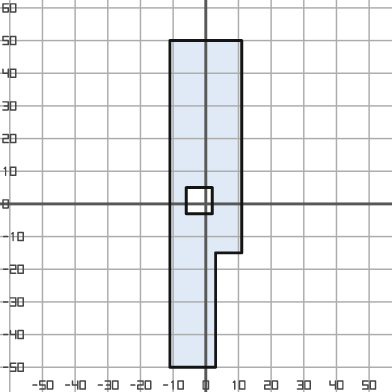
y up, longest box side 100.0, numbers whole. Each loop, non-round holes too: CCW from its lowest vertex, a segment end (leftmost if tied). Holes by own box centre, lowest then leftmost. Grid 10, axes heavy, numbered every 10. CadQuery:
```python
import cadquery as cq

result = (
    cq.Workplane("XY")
    .moveTo(-11.0, -50.0)
    .lineTo(3.0, -50.0)
    .lineTo(3.0, -15.0)
    .lineTo(11.0, -15.0)
    .lineTo(11.0, 50.0)
    .lineTo(-11.0, 50.0)
    .close()
    .moveTo(-6.0, -3.0)
    .lineTo(2.0, -3.0)
    .lineTo(2.0, 5.0)
    .lineTo(-6.0, 5.0)
    .close()
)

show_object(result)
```